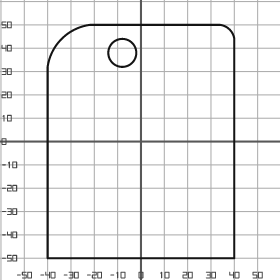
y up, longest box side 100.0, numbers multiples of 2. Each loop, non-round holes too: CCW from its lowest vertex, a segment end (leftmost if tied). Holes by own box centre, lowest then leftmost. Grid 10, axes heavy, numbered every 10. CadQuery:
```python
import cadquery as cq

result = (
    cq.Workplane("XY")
    .moveTo(-40.0, -50.0)
    .lineTo(40.0, -50.0)
    .lineTo(40.0, 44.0)
    .threePointArc((38.0, 48.0), (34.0, 50.0))
    .lineTo(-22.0, 50.0)
    .threePointArc((-34.0, 44.0), (-40.0, 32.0))
    .close()
    .moveTo(-8.0, 38.0)
    .circle(6.0)
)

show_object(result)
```